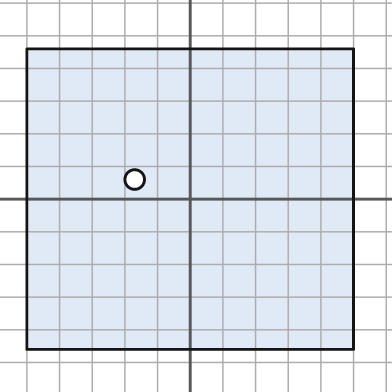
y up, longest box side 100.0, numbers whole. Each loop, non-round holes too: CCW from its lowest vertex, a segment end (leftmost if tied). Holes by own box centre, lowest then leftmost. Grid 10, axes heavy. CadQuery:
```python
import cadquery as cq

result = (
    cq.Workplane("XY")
    .moveTo(-50.0, -46.0)
    .lineTo(50.0, -46.0)
    .lineTo(50.0, 46.0)
    .lineTo(-50.0, 46.0)
    .close()
    .moveTo(-17.0, 6.0)
    .circle(3.0)
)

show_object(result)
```